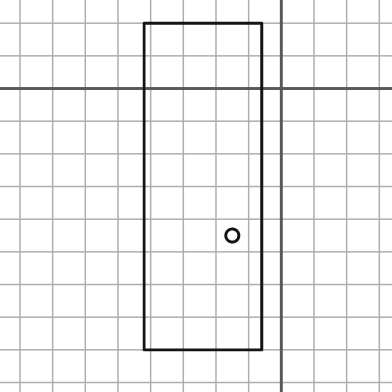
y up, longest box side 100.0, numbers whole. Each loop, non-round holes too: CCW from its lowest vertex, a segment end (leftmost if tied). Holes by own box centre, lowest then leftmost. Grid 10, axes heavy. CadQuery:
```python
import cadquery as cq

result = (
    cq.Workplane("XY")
    .moveTo(-42.0, -80.0)
    .lineTo(-6.0, -80.0)
    .lineTo(-6.0, 20.0)
    .lineTo(-42.0, 20.0)
    .close()
    .moveTo(-15.0, -45.0)
    .circle(2.0)
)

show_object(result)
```